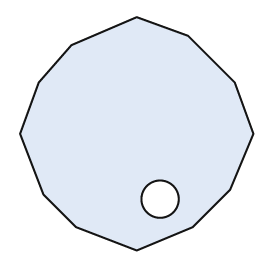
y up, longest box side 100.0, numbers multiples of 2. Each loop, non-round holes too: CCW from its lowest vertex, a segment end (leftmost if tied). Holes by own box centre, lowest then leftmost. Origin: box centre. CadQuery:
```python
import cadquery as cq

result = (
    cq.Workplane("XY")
    .moveTo(0.0, -50.0)
    .lineTo(24.0, -40.0)
    .lineTo(40.0, -24.0)
    .lineTo(50.0, 0.0)
    .lineTo(42.0, 22.0)
    .lineTo(22.0, 42.0)
    .lineTo(0.0, 50.0)
    .lineTo(-28.0, 38.0)
    .lineTo(-42.0, 22.0)
    .lineTo(-50.0, 0.0)
    .lineTo(-40.0, -26.0)
    .lineTo(-26.0, -40.0)
    .close()
    .moveTo(10.0, -28.0)
    .circle(8.0)
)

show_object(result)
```